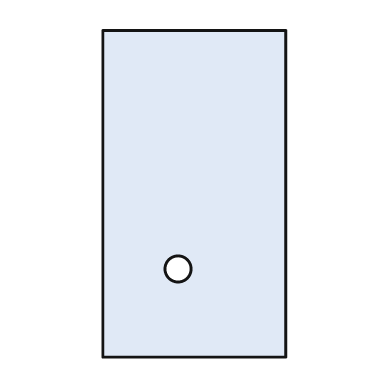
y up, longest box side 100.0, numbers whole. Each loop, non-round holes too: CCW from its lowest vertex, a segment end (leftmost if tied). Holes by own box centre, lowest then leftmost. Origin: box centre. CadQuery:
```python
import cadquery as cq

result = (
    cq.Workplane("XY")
    .moveTo(-28.0, -50.0)
    .lineTo(28.0, -50.0)
    .lineTo(28.0, 50.0)
    .lineTo(-28.0, 50.0)
    .close()
    .moveTo(-5.0, -23.0)
    .circle(4.0)
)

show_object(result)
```